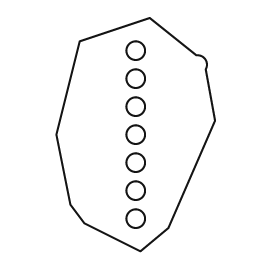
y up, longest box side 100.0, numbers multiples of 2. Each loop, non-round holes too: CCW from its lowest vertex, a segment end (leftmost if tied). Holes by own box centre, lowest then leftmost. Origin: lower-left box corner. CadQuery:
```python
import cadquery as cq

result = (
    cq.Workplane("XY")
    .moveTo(36.0, 0.0)
    .lineTo(48.0, 10.0)
    .lineTo(68.0, 56.0)
    .lineTo(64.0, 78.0)
    .threePointArc((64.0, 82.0), (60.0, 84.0))
    .lineTo(40.0, 100.0)
    .lineTo(10.0, 90.0)
    .lineTo(0.0, 50.0)
    .lineTo(6.0, 20.0)
    .lineTo(12.0, 12.0)
    .close()
    .moveTo(34.0, 14.0)
    .circle(4.0)
    .moveTo(34.0, 26.0)
    .circle(4.0)
    .moveTo(34.0, 38.0)
    .circle(4.0)
    .moveTo(34.0, 50.0)
    .circle(4.0)
    .moveTo(34.0, 62.0)
    .circle(4.0)
    .moveTo(34.0, 74.0)
    .circle(4.0)
    .moveTo(34.0, 86.0)
    .circle(4.0)
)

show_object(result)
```